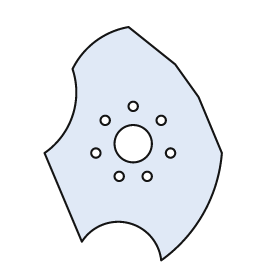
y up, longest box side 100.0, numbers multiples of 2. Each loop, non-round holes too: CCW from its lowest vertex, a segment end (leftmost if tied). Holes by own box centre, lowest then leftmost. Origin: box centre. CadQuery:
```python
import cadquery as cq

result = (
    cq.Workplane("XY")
    .moveTo(12.0, -50.0)
    .threePointArc((30.0, -30.0), (38.0, -4.0))
    .lineTo(28.0, 20.0)
    .lineTo(18.0, 34.0)
    .lineTo(-2.0, 50.0)
    .threePointArc((-16.0, 44.0), (-26.0, 32.0))
    .threePointArc((-26.0, 12.0), (-38.0, -4.0))
    .lineTo(-22.0, -42.0)
    .threePointArc((-2.0, -34.0), (12.0, -50.0))
    .close()
    .moveTo(-6.0, -14.0)
    .circle(2.0)
    .moveTo(6.0, -14.0)
    .circle(2.0)
    .moveTo(-16.0, -4.0)
    .circle(2.0)
    .moveTo(16.0, -4.0)
    .circle(2.0)
    .moveTo(0.0, 0.0)
    .circle(8.0)
    .moveTo(-12.0, 10.0)
    .circle(2.0)
    .moveTo(12.0, 10.0)
    .circle(2.0)
    .moveTo(0.0, 16.0)
    .circle(2.0)
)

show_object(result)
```